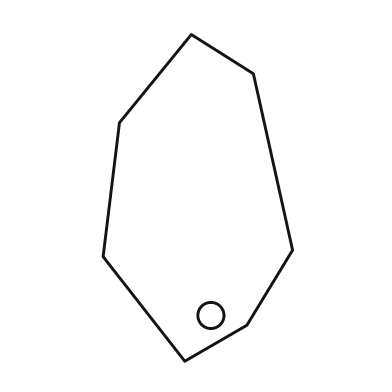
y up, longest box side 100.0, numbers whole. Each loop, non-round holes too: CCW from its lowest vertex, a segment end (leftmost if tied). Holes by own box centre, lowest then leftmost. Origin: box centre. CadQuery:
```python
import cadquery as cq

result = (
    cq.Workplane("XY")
    .moveTo(-4.0, -50.0)
    .lineTo(15.0, -39.0)
    .lineTo(29.0, -16.0)
    .lineTo(17.0, 38.0)
    .lineTo(-2.0, 50.0)
    .lineTo(-24.0, 23.0)
    .lineTo(-29.0, -18.0)
    .close()
    .moveTo(4.0, -36.0)
    .circle(4.0)
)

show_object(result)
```